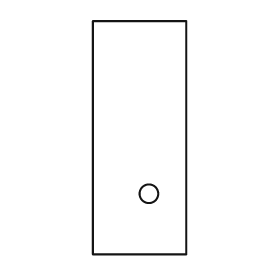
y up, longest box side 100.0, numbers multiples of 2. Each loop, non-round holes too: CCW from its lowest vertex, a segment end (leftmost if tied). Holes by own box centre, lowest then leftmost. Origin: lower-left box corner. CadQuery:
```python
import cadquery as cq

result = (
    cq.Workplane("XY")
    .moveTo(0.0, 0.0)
    .lineTo(40.0, 0.0)
    .lineTo(40.0, 100.0)
    .lineTo(0.0, 100.0)
    .close()
    .moveTo(24.0, 26.0)
    .circle(4.0)
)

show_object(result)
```